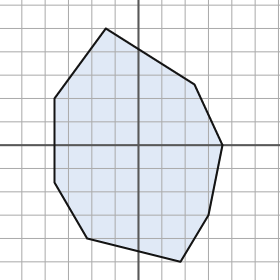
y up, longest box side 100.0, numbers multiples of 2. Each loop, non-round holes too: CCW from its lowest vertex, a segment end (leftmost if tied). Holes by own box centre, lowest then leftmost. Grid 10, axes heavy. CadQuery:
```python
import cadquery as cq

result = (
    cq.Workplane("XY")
    .moveTo(18.0, -50.0)
    .lineTo(30.0, -30.0)
    .lineTo(36.0, 0.0)
    .lineTo(24.0, 26.0)
    .lineTo(-14.0, 50.0)
    .lineTo(-36.0, 20.0)
    .lineTo(-36.0, -16.0)
    .lineTo(-22.0, -40.0)
    .close()
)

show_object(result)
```